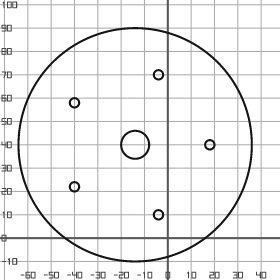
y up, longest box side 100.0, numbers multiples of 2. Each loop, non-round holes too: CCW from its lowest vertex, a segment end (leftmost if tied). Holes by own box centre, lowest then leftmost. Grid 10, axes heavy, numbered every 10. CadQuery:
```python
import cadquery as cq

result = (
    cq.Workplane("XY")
    .moveTo(-14.0, 40.0)
    .circle(50.0)
    .moveTo(-4.0, 10.0)
    .circle(2.0)
    .moveTo(-40.0, 22.0)
    .circle(2.0)
    .moveTo(-14.0, 40.0)
    .circle(6.0)
    .moveTo(18.0, 40.0)
    .circle(2.0)
    .moveTo(-40.0, 58.0)
    .circle(2.0)
    .moveTo(-4.0, 70.0)
    .circle(2.0)
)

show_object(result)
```